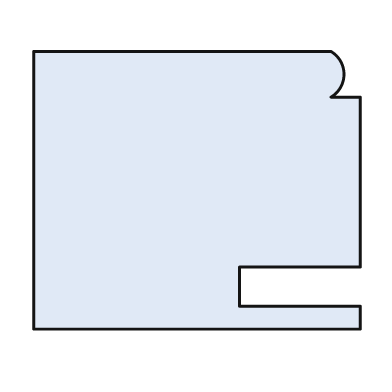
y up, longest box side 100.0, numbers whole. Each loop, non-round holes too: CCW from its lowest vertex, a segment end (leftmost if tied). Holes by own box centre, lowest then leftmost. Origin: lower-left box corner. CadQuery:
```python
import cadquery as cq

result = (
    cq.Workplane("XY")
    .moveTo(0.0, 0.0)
    .lineTo(100.0, 0.0)
    .lineTo(100.0, 7.0)
    .lineTo(63.0, 7.0)
    .lineTo(63.0, 19.0)
    .lineTo(100.0, 19.0)
    .lineTo(100.0, 71.0)
    .lineTo(91.0, 71.0)
    .threePointArc((95.0, 78.0), (91.0, 85.0))
    .lineTo(0.0, 85.0)
    .close()
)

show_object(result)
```